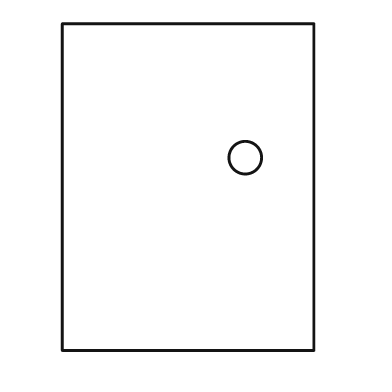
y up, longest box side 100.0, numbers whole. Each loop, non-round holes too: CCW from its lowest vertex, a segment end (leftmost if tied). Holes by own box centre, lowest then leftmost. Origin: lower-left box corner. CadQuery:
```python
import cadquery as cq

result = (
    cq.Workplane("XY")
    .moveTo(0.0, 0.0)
    .lineTo(77.0, 0.0)
    .lineTo(77.0, 100.0)
    .lineTo(0.0, 100.0)
    .close()
    .moveTo(56.0, 59.0)
    .circle(5.0)
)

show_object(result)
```